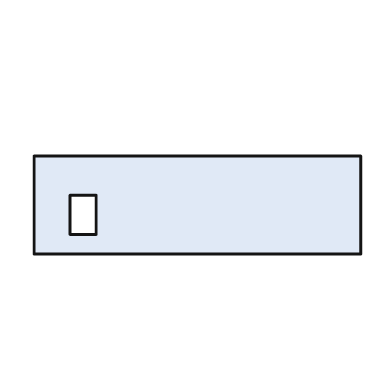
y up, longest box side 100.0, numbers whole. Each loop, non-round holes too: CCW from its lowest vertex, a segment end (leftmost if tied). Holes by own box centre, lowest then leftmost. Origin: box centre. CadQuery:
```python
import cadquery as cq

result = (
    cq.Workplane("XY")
    .moveTo(-50.0, -15.0)
    .lineTo(50.0, -15.0)
    .lineTo(50.0, 15.0)
    .lineTo(-50.0, 15.0)
    .close()
    .moveTo(-39.0, -9.0)
    .lineTo(-31.0, -9.0)
    .lineTo(-31.0, 3.0)
    .lineTo(-39.0, 3.0)
    .close()
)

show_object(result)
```